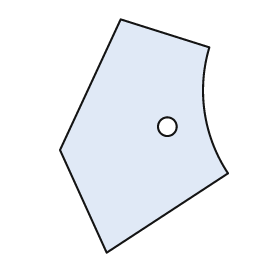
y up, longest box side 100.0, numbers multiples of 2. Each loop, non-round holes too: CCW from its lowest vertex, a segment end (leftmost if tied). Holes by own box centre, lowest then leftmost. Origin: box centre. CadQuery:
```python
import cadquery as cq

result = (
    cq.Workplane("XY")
    .moveTo(-16.0, -50.0)
    .lineTo(36.0, -16.0)
    .threePointArc((26.0, 10.0), (28.0, 38.0))
    .lineTo(-10.0, 50.0)
    .lineTo(-36.0, -6.0)
    .close()
    .moveTo(10.0, 4.0)
    .circle(4.0)
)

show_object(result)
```